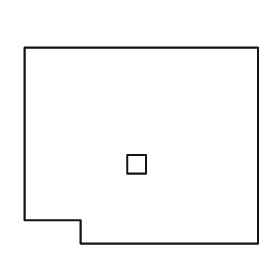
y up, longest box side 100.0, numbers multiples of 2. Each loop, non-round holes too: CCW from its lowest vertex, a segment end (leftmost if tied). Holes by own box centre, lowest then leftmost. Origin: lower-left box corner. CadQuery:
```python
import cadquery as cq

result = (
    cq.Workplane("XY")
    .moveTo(24.0, 0.0)
    .lineTo(100.0, 0.0)
    .lineTo(100.0, 84.0)
    .lineTo(0.0, 84.0)
    .lineTo(0.0, 10.0)
    .lineTo(24.0, 10.0)
    .close()
    .moveTo(44.0, 30.0)
    .lineTo(52.0, 30.0)
    .lineTo(52.0, 38.0)
    .lineTo(44.0, 38.0)
    .close()
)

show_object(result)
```